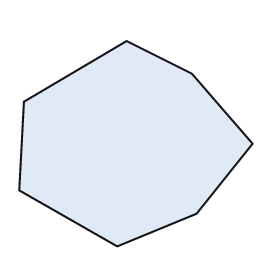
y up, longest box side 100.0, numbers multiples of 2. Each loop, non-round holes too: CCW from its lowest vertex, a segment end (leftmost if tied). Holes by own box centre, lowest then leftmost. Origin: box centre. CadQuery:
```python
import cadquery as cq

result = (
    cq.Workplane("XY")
    .moveTo(-8.0, -44.0)
    .lineTo(26.0, -30.0)
    .lineTo(50.0, 0.0)
    .lineTo(24.0, 30.0)
    .lineTo(-4.0, 44.0)
    .lineTo(-48.0, 18.0)
    .lineTo(-50.0, -20.0)
    .close()
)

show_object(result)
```